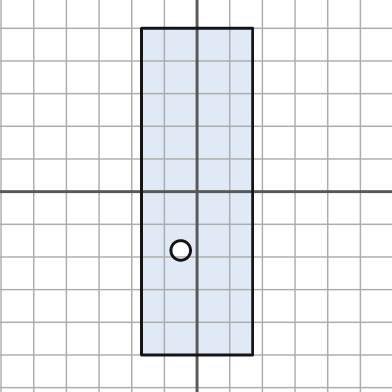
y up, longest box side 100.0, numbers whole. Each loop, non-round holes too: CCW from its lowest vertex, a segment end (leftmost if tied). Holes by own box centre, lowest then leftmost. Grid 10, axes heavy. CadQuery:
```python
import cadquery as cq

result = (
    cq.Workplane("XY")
    .moveTo(-17.0, -50.0)
    .lineTo(17.0, -50.0)
    .lineTo(17.0, 50.0)
    .lineTo(-17.0, 50.0)
    .close()
    .moveTo(-5.0, -18.0)
    .circle(3.0)
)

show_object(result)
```